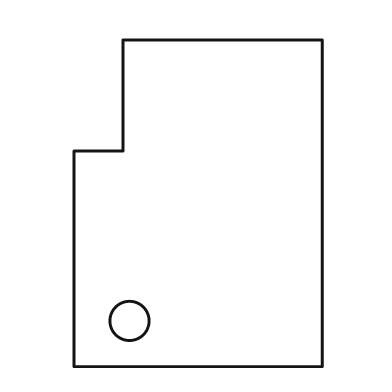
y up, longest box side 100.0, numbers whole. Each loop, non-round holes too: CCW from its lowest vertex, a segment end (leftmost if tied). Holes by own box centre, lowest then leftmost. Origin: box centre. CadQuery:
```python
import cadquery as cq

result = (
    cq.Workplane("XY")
    .moveTo(-38.0, -50.0)
    .lineTo(38.0, -50.0)
    .lineTo(38.0, 50.0)
    .lineTo(-23.0, 50.0)
    .lineTo(-23.0, 16.0)
    .lineTo(-38.0, 16.0)
    .close()
    .moveTo(-21.0, -36.0)
    .circle(6.0)
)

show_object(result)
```